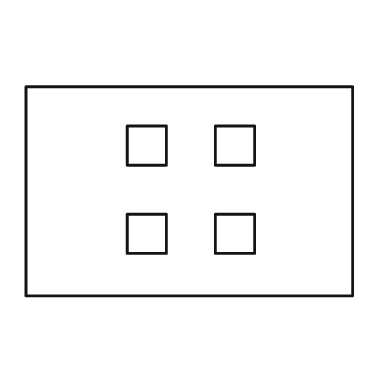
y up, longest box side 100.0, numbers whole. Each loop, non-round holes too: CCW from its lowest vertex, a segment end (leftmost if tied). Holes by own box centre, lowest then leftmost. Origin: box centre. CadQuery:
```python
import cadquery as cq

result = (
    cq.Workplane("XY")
    .moveTo(-50.0, -32.0)
    .lineTo(50.0, -32.0)
    .lineTo(50.0, 32.0)
    .lineTo(-50.0, 32.0)
    .close()
    .moveTo(-19.0, -19.0)
    .lineTo(-7.0, -19.0)
    .lineTo(-7.0, -7.0)
    .lineTo(-19.0, -7.0)
    .close()
    .moveTo(8.0, -19.0)
    .lineTo(20.0, -19.0)
    .lineTo(20.0, -7.0)
    .lineTo(8.0, -7.0)
    .close()
    .moveTo(-19.0, 8.0)
    .lineTo(-7.0, 8.0)
    .lineTo(-7.0, 20.0)
    .lineTo(-19.0, 20.0)
    .close()
    .moveTo(8.0, 8.0)
    .lineTo(20.0, 8.0)
    .lineTo(20.0, 20.0)
    .lineTo(8.0, 20.0)
    .close()
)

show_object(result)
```